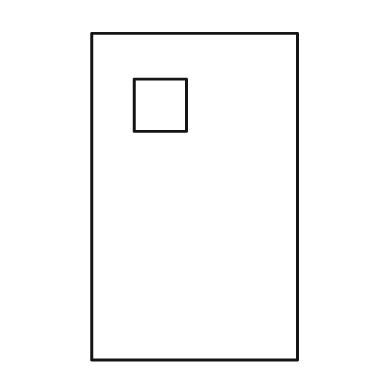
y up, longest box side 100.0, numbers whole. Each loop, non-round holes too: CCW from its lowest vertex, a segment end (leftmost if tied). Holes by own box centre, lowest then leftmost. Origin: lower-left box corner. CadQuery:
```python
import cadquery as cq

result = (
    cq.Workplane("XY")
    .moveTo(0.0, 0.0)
    .lineTo(63.0, 0.0)
    .lineTo(63.0, 100.0)
    .lineTo(0.0, 100.0)
    .close()
    .moveTo(13.0, 70.0)
    .lineTo(29.0, 70.0)
    .lineTo(29.0, 86.0)
    .lineTo(13.0, 86.0)
    .close()
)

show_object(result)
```